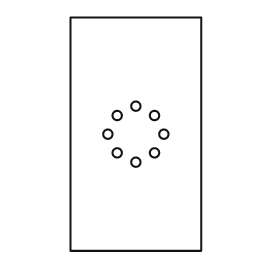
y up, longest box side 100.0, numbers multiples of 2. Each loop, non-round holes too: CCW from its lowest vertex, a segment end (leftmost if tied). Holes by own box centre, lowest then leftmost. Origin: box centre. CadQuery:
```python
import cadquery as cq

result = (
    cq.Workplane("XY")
    .moveTo(-28.0, -50.0)
    .lineTo(28.0, -50.0)
    .lineTo(28.0, 50.0)
    .lineTo(-28.0, 50.0)
    .close()
    .moveTo(0.0, -12.0)
    .circle(2.0)
    .moveTo(-8.0, -8.0)
    .circle(2.0)
    .moveTo(8.0, -8.0)
    .circle(2.0)
    .moveTo(-12.0, 0.0)
    .circle(2.0)
    .moveTo(12.0, 0.0)
    .circle(2.0)
    .moveTo(-8.0, 8.0)
    .circle(2.0)
    .moveTo(8.0, 8.0)
    .circle(2.0)
    .moveTo(0.0, 12.0)
    .circle(2.0)
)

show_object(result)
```